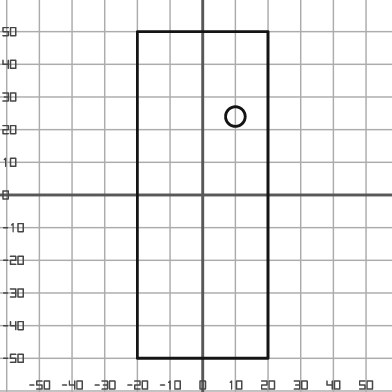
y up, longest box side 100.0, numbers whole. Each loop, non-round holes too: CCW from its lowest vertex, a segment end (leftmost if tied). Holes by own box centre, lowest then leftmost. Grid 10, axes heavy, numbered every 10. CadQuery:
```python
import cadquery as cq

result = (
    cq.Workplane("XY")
    .moveTo(-20.0, -50.0)
    .lineTo(20.0, -50.0)
    .lineTo(20.0, 50.0)
    .lineTo(-20.0, 50.0)
    .close()
    .moveTo(10.0, 24.0)
    .circle(3.0)
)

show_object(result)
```